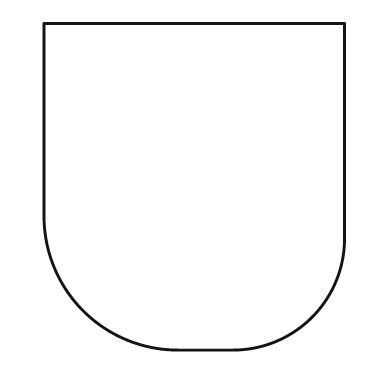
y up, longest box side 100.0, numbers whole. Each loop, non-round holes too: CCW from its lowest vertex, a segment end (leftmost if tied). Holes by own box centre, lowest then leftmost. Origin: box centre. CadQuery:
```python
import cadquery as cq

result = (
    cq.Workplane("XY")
    .moveTo(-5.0, -50.0)
    .lineTo(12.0, -50.0)
    .threePointArc((36.0, -40.0), (46.0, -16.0))
    .lineTo(46.0, 50.0)
    .lineTo(-46.0, 50.0)
    .lineTo(-46.0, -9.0)
    .threePointArc((-34.0, -38.0), (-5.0, -50.0))
    .close()
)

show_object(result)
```